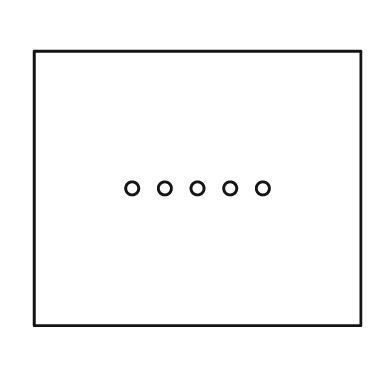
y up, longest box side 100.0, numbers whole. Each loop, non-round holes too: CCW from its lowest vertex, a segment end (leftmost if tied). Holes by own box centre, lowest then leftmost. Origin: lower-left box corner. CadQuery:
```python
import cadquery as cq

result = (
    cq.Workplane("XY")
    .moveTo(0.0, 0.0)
    .lineTo(100.0, 0.0)
    .lineTo(100.0, 84.0)
    .lineTo(0.0, 84.0)
    .close()
    .moveTo(30.0, 42.0)
    .circle(2.0)
    .moveTo(40.0, 42.0)
    .circle(2.0)
    .moveTo(50.0, 42.0)
    .circle(2.0)
    .moveTo(60.0, 42.0)
    .circle(2.0)
    .moveTo(70.0, 42.0)
    .circle(2.0)
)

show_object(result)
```